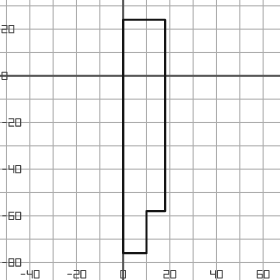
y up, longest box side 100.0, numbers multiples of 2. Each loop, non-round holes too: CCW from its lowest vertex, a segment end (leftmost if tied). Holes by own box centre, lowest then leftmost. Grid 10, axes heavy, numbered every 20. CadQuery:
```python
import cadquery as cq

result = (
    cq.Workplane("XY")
    .moveTo(0.0, -76.0)
    .lineTo(10.0, -76.0)
    .lineTo(10.0, -58.0)
    .lineTo(18.0, -58.0)
    .lineTo(18.0, 24.0)
    .lineTo(0.0, 24.0)
    .close()
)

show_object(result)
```